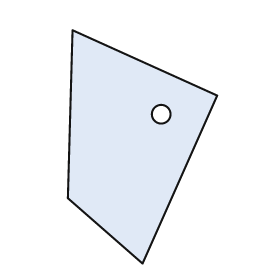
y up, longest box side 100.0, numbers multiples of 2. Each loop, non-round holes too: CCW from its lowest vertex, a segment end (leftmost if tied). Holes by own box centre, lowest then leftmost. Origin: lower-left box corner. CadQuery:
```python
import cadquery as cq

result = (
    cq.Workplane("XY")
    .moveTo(32.0, 0.0)
    .lineTo(64.0, 72.0)
    .lineTo(2.0, 100.0)
    .lineTo(0.0, 28.0)
    .close()
    .moveTo(40.0, 64.0)
    .circle(4.0)
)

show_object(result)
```